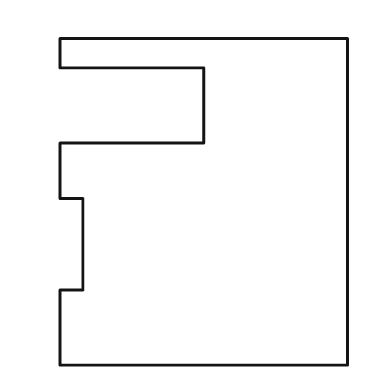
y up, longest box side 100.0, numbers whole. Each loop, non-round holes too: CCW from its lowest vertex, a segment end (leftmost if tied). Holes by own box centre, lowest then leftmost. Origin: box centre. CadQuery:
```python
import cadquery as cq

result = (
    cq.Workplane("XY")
    .moveTo(-44.0, -50.0)
    .lineTo(44.0, -50.0)
    .lineTo(44.0, 50.0)
    .lineTo(-44.0, 50.0)
    .lineTo(-44.0, 41.0)
    .lineTo(0.0, 41.0)
    .lineTo(0.0, 18.0)
    .lineTo(-44.0, 18.0)
    .lineTo(-44.0, 1.0)
    .lineTo(-37.0, 1.0)
    .lineTo(-37.0, -27.0)
    .lineTo(-44.0, -27.0)
    .close()
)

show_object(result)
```